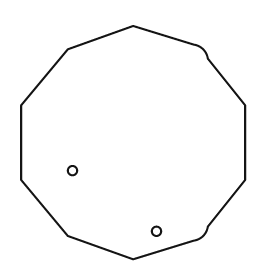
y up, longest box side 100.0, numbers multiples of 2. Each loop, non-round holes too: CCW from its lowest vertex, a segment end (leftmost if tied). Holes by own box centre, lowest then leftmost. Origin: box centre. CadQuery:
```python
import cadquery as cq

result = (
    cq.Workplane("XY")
    .moveTo(0.0, -50.0)
    .lineTo(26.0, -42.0)
    .threePointArc((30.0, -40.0), (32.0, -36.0))
    .lineTo(48.0, -16.0)
    .lineTo(48.0, 16.0)
    .lineTo(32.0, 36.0)
    .threePointArc((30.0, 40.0), (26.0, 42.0))
    .lineTo(0.0, 50.0)
    .lineTo(-28.0, 40.0)
    .lineTo(-48.0, 16.0)
    .lineTo(-48.0, -16.0)
    .lineTo(-28.0, -40.0)
    .close()
    .moveTo(10.0, -38.0)
    .circle(2.0)
    .moveTo(-26.0, -12.0)
    .circle(2.0)
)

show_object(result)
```